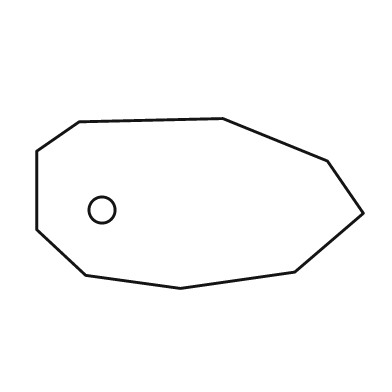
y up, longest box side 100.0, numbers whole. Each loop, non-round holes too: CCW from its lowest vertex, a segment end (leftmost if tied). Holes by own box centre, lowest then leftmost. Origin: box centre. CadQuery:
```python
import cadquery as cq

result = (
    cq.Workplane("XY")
    .moveTo(-6.0, -26.0)
    .lineTo(29.0, -21.0)
    .lineTo(50.0, -3.0)
    .lineTo(39.0, 13.0)
    .lineTo(7.0, 26.0)
    .lineTo(-37.0, 25.0)
    .lineTo(-50.0, 16.0)
    .lineTo(-50.0, -8.0)
    .lineTo(-35.0, -22.0)
    .close()
    .moveTo(-30.0, -2.0)
    .circle(4.0)
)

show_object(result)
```